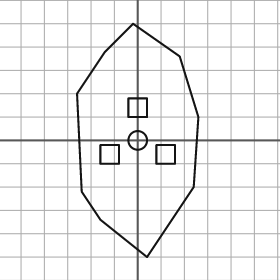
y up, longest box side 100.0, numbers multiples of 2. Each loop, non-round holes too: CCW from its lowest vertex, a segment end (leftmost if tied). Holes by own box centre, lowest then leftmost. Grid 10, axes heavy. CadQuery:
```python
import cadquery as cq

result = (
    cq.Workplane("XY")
    .moveTo(4.0, -50.0)
    .lineTo(24.0, -20.0)
    .lineTo(26.0, 10.0)
    .lineTo(18.0, 36.0)
    .lineTo(-2.0, 50.0)
    .lineTo(-14.0, 38.0)
    .lineTo(-26.0, 20.0)
    .lineTo(-24.0, -22.0)
    .lineTo(-16.0, -34.0)
    .close()
    .moveTo(-16.0, -10.0)
    .lineTo(-8.0, -10.0)
    .lineTo(-8.0, -2.0)
    .lineTo(-16.0, -2.0)
    .close()
    .moveTo(8.0, -10.0)
    .lineTo(16.0, -10.0)
    .lineTo(16.0, -2.0)
    .lineTo(8.0, -2.0)
    .close()
    .moveTo(0.0, 0.0)
    .circle(4.0)
    .moveTo(-4.0, 10.0)
    .lineTo(4.0, 10.0)
    .lineTo(4.0, 18.0)
    .lineTo(-4.0, 18.0)
    .close()
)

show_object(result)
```